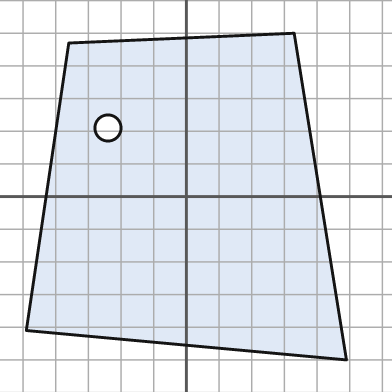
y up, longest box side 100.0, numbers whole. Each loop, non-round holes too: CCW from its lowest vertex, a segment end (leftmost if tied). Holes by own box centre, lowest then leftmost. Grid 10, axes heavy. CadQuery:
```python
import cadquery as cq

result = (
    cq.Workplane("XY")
    .moveTo(49.0, -50.0)
    .lineTo(33.0, 50.0)
    .lineTo(-36.0, 47.0)
    .lineTo(-49.0, -41.0)
    .close()
    .moveTo(-24.0, 21.0)
    .circle(4.0)
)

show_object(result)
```